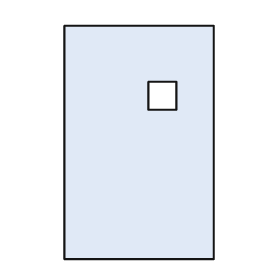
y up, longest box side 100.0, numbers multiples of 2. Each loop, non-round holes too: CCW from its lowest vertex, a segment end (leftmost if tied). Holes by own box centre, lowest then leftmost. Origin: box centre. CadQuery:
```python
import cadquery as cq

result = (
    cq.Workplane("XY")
    .moveTo(-32.0, -50.0)
    .lineTo(32.0, -50.0)
    .lineTo(32.0, 50.0)
    .lineTo(-32.0, 50.0)
    .close()
    .moveTo(4.0, 14.0)
    .lineTo(16.0, 14.0)
    .lineTo(16.0, 26.0)
    .lineTo(4.0, 26.0)
    .close()
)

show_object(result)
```